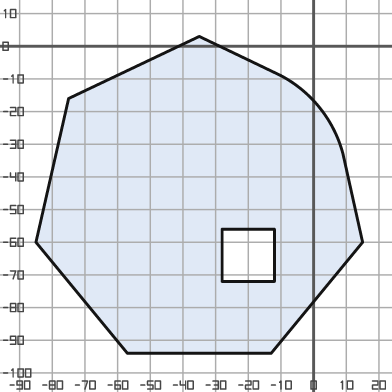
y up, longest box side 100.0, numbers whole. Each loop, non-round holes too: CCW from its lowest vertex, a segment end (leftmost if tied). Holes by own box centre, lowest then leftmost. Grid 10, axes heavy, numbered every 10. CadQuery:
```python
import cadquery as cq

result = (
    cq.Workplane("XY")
    .moveTo(-57.0, -94.0)
    .lineTo(-13.0, -94.0)
    .lineTo(15.0, -60.0)
    .lineTo(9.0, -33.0)
    .threePointArc((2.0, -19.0), (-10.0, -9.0))
    .lineTo(-35.0, 3.0)
    .lineTo(-75.0, -16.0)
    .lineTo(-85.0, -60.0)
    .close()
    .moveTo(-28.0, -72.0)
    .lineTo(-12.0, -72.0)
    .lineTo(-12.0, -56.0)
    .lineTo(-28.0, -56.0)
    .close()
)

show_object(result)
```